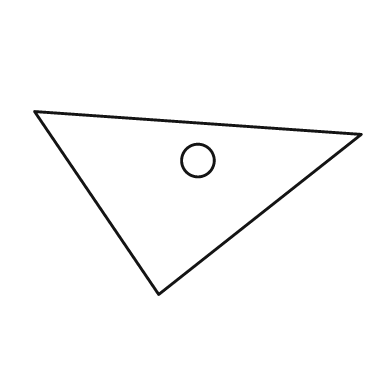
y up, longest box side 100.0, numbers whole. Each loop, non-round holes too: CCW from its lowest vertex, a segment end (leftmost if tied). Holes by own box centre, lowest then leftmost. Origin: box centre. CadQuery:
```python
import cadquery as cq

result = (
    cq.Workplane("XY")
    .moveTo(-12.0, -28.0)
    .lineTo(50.0, 21.0)
    .lineTo(-50.0, 28.0)
    .close()
    .moveTo(0.0, 13.0)
    .circle(5.0)
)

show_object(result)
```